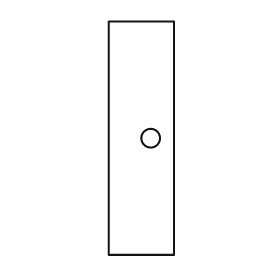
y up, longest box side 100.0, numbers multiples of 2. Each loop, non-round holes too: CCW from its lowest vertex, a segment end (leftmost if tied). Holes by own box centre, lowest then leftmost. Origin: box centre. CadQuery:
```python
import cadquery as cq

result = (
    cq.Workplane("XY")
    .moveTo(-14.0, -50.0)
    .lineTo(14.0, -50.0)
    .lineTo(14.0, 50.0)
    .lineTo(-14.0, 50.0)
    .close()
    .moveTo(4.0, 0.0)
    .circle(4.0)
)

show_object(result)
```